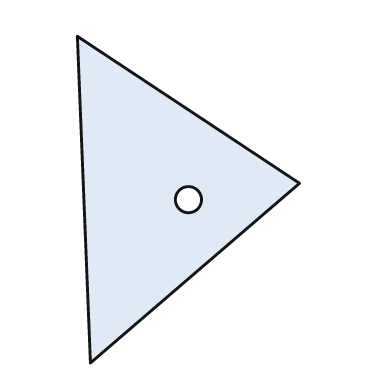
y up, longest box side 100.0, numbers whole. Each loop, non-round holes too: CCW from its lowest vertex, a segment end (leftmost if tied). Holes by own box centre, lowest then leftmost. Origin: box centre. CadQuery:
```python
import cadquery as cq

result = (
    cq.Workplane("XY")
    .moveTo(-30.0, -50.0)
    .lineTo(34.0, 5.0)
    .lineTo(-34.0, 50.0)
    .close()
    .moveTo(0.0, 0.0)
    .circle(4.0)
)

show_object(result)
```